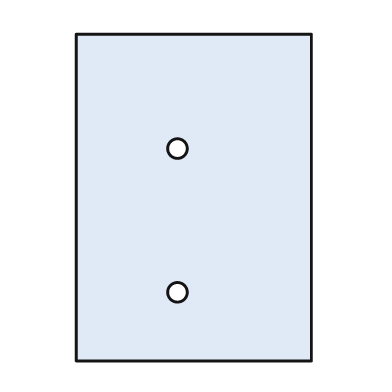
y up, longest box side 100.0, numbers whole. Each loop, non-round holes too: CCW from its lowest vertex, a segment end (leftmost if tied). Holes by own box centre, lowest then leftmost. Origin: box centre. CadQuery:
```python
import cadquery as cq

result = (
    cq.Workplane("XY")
    .moveTo(-36.0, -50.0)
    .lineTo(36.0, -50.0)
    .lineTo(36.0, 50.0)
    .lineTo(-36.0, 50.0)
    .close()
    .moveTo(-5.0, -29.0)
    .circle(3.0)
    .moveTo(-5.0, 15.0)
    .circle(3.0)
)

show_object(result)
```